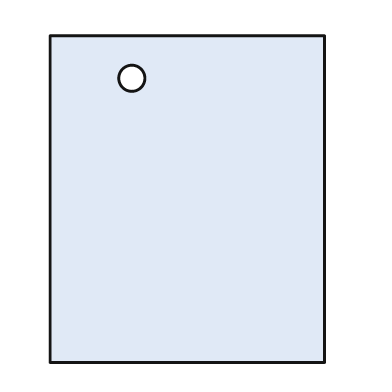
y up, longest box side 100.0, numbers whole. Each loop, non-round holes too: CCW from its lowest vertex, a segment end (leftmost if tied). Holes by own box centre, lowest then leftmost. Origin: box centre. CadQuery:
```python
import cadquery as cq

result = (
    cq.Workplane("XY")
    .moveTo(-42.0, -50.0)
    .lineTo(42.0, -50.0)
    .lineTo(42.0, 50.0)
    .lineTo(-42.0, 50.0)
    .close()
    .moveTo(-17.0, 37.0)
    .circle(4.0)
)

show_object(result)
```